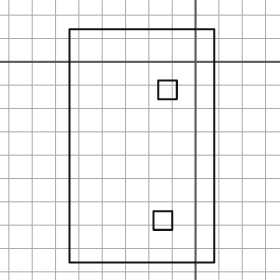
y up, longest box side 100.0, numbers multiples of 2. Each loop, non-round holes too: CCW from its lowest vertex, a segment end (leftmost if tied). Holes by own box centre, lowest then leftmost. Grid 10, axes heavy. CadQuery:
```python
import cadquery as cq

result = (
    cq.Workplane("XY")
    .moveTo(-54.0, -86.0)
    .lineTo(8.0, -86.0)
    .lineTo(8.0, 14.0)
    .lineTo(-54.0, 14.0)
    .close()
    .moveTo(-18.0, -72.0)
    .lineTo(-10.0, -72.0)
    .lineTo(-10.0, -64.0)
    .lineTo(-18.0, -64.0)
    .close()
    .moveTo(-16.0, -16.0)
    .lineTo(-8.0, -16.0)
    .lineTo(-8.0, -8.0)
    .lineTo(-16.0, -8.0)
    .close()
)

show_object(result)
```